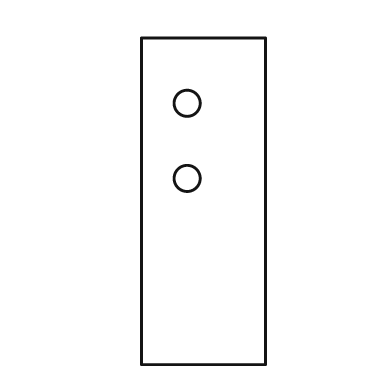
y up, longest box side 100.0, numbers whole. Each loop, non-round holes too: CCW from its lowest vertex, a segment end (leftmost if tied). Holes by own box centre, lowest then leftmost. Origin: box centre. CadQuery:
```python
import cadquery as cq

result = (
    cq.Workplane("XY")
    .moveTo(-19.0, -50.0)
    .lineTo(19.0, -50.0)
    .lineTo(19.0, 50.0)
    .lineTo(-19.0, 50.0)
    .close()
    .moveTo(-5.0, 7.0)
    .circle(4.0)
    .moveTo(-5.0, 30.0)
    .circle(4.0)
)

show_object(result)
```